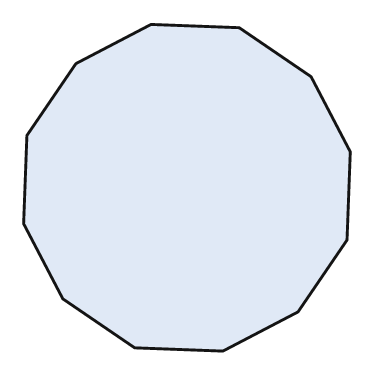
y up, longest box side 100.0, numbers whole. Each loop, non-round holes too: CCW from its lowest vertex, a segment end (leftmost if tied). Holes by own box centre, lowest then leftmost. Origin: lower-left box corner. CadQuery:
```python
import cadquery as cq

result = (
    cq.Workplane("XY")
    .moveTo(61.0, 0.0)
    .lineTo(84.0, 12.0)
    .lineTo(99.0, 34.0)
    .lineTo(100.0, 61.0)
    .lineTo(88.0, 84.0)
    .lineTo(66.0, 99.0)
    .lineTo(39.0, 100.0)
    .lineTo(16.0, 88.0)
    .lineTo(1.0, 66.0)
    .lineTo(0.0, 39.0)
    .lineTo(12.0, 16.0)
    .lineTo(34.0, 1.0)
    .close()
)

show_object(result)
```